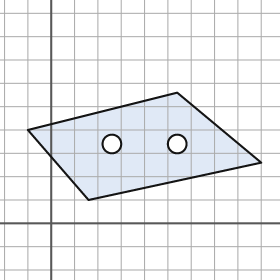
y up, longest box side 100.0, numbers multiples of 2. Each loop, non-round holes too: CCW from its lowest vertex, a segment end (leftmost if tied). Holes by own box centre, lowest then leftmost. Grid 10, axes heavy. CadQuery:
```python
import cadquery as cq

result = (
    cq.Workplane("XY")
    .moveTo(16.0, 10.0)
    .lineTo(90.0, 26.0)
    .lineTo(54.0, 56.0)
    .lineTo(-10.0, 40.0)
    .close()
    .moveTo(26.0, 34.0)
    .circle(4.0)
    .moveTo(54.0, 34.0)
    .circle(4.0)
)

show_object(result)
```